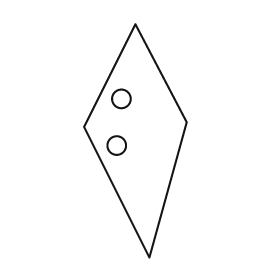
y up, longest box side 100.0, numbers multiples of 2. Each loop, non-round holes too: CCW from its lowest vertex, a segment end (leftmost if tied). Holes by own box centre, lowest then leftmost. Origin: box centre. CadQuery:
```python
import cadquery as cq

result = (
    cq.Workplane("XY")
    .moveTo(6.0, -50.0)
    .lineTo(22.0, 8.0)
    .lineTo(0.0, 50.0)
    .lineTo(-22.0, 6.0)
    .close()
    .moveTo(-8.0, -2.0)
    .circle(4.0)
    .moveTo(-6.0, 18.0)
    .circle(4.0)
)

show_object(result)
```